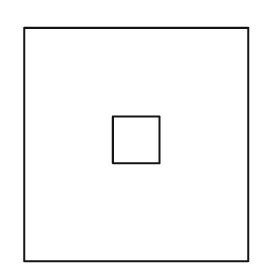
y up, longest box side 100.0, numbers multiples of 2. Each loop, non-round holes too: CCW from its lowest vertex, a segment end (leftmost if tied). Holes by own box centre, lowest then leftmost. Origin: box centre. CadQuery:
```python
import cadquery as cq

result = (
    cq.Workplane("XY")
    .moveTo(-48.0, -50.0)
    .lineTo(48.0, -50.0)
    .lineTo(48.0, 50.0)
    .lineTo(-48.0, 50.0)
    .close()
    .moveTo(-10.0, -8.0)
    .lineTo(10.0, -8.0)
    .lineTo(10.0, 12.0)
    .lineTo(-10.0, 12.0)
    .close()
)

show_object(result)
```